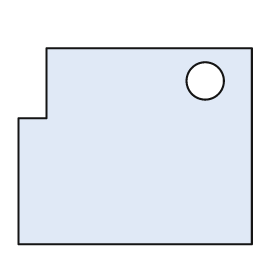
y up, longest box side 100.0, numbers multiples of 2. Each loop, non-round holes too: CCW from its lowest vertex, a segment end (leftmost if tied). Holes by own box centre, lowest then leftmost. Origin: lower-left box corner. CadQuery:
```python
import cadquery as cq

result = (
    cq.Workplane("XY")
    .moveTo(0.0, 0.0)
    .lineTo(100.0, 0.0)
    .lineTo(100.0, 84.0)
    .lineTo(12.0, 84.0)
    .lineTo(12.0, 54.0)
    .lineTo(0.0, 54.0)
    .close()
    .moveTo(80.0, 70.0)
    .circle(8.0)
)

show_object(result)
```